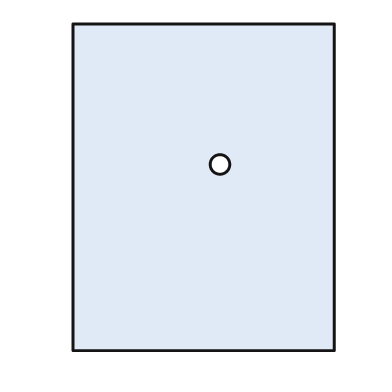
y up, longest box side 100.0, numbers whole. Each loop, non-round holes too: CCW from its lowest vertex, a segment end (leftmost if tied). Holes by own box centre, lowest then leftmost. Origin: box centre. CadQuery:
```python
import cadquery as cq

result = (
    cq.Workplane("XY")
    .moveTo(-40.0, -50.0)
    .lineTo(40.0, -50.0)
    .lineTo(40.0, 50.0)
    .lineTo(-40.0, 50.0)
    .close()
    .moveTo(5.0, 7.0)
    .circle(3.0)
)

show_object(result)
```